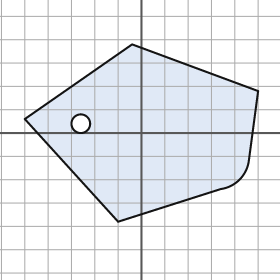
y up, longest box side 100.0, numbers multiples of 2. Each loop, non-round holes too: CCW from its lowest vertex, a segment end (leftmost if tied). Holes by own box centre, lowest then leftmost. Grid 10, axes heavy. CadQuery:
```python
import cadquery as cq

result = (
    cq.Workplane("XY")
    .moveTo(-10.0, -38.0)
    .lineTo(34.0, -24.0)
    .threePointArc((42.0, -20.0), (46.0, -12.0))
    .lineTo(50.0, 18.0)
    .lineTo(-4.0, 38.0)
    .lineTo(-50.0, 6.0)
    .close()
    .moveTo(-26.0, 4.0)
    .circle(4.0)
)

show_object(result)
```